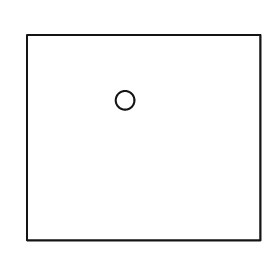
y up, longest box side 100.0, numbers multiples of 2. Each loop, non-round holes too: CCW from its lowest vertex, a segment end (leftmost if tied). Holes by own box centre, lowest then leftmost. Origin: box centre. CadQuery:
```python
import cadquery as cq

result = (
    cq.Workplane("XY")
    .moveTo(-50.0, -44.0)
    .lineTo(50.0, -44.0)
    .lineTo(50.0, 44.0)
    .lineTo(-50.0, 44.0)
    .close()
    .moveTo(-8.0, 16.0)
    .circle(4.0)
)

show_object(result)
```